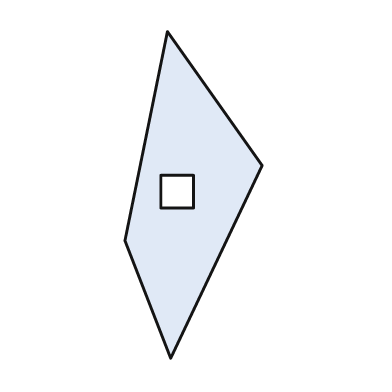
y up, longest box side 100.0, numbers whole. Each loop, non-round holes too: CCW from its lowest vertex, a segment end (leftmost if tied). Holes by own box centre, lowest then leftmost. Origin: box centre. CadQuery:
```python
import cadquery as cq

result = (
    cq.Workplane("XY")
    .moveTo(-7.0, -50.0)
    .lineTo(21.0, 9.0)
    .lineTo(-8.0, 50.0)
    .lineTo(-21.0, -14.0)
    .close()
    .moveTo(-10.0, -4.0)
    .lineTo(0.0, -4.0)
    .lineTo(0.0, 6.0)
    .lineTo(-10.0, 6.0)
    .close()
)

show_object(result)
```